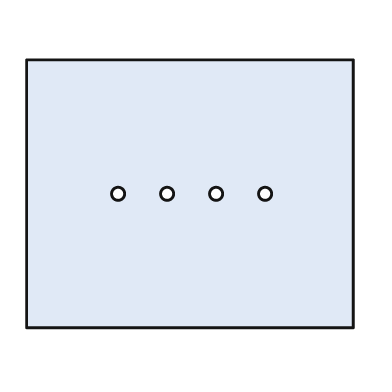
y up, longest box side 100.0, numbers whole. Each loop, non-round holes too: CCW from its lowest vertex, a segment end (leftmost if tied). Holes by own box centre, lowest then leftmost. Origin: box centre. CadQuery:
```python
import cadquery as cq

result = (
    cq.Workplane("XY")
    .moveTo(-50.0, -41.0)
    .lineTo(50.0, -41.0)
    .lineTo(50.0, 41.0)
    .lineTo(-50.0, 41.0)
    .close()
    .moveTo(-22.0, 0.0)
    .circle(2.0)
    .moveTo(-7.0, 0.0)
    .circle(2.0)
    .moveTo(8.0, 0.0)
    .circle(2.0)
    .moveTo(23.0, 0.0)
    .circle(2.0)
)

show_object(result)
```